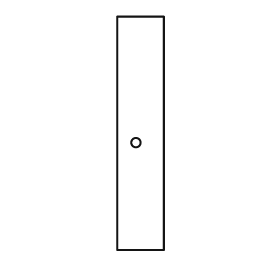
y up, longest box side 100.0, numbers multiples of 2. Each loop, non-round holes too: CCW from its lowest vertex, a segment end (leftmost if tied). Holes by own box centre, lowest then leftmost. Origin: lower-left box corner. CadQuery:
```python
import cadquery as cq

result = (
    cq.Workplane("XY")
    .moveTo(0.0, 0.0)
    .lineTo(20.0, 0.0)
    .lineTo(20.0, 100.0)
    .lineTo(0.0, 100.0)
    .close()
    .moveTo(8.0, 46.0)
    .circle(2.0)
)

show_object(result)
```